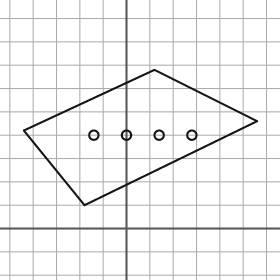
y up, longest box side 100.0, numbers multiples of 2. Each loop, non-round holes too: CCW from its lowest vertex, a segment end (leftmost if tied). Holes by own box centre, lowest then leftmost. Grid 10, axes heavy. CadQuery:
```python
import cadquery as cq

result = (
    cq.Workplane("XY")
    .moveTo(-18.0, 10.0)
    .lineTo(56.0, 46.0)
    .lineTo(12.0, 68.0)
    .lineTo(-44.0, 42.0)
    .close()
    .moveTo(-14.0, 40.0)
    .circle(2.0)
    .moveTo(0.0, 40.0)
    .circle(2.0)
    .moveTo(14.0, 40.0)
    .circle(2.0)
    .moveTo(28.0, 40.0)
    .circle(2.0)
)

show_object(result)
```